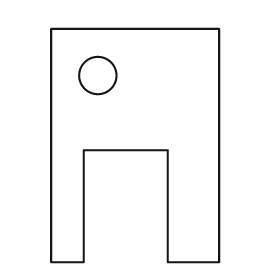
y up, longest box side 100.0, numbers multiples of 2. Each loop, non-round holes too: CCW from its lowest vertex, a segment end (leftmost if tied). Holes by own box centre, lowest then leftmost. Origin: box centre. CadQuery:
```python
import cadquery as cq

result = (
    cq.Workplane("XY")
    .moveTo(-36.0, -50.0)
    .lineTo(-22.0, -50.0)
    .lineTo(-22.0, -2.0)
    .lineTo(14.0, -2.0)
    .lineTo(14.0, -50.0)
    .lineTo(36.0, -50.0)
    .lineTo(36.0, 50.0)
    .lineTo(-36.0, 50.0)
    .close()
    .moveTo(-16.0, 30.0)
    .circle(8.0)
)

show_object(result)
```